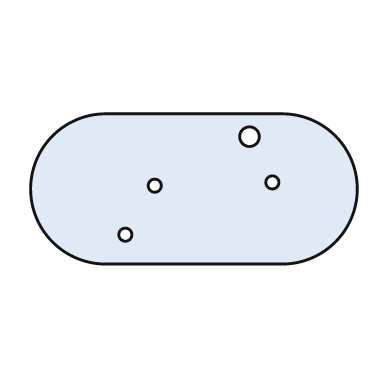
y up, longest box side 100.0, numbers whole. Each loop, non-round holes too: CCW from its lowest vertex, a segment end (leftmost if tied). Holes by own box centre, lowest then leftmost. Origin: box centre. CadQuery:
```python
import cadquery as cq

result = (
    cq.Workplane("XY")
    .moveTo(-27.0, -23.0)
    .lineTo(27.0, -23.0)
    .threePointArc((50.0, 0.0), (27.0, 23.0))
    .lineTo(-27.0, 23.0)
    .threePointArc((-50.0, 0.0), (-27.0, -23.0))
    .close()
    .moveTo(-21.0, -14.0)
    .circle(2.0)
    .moveTo(-12.0, 1.0)
    .circle(2.0)
    .moveTo(24.0, 2.0)
    .circle(2.0)
    .moveTo(17.0, 16.0)
    .circle(3.0)
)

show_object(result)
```